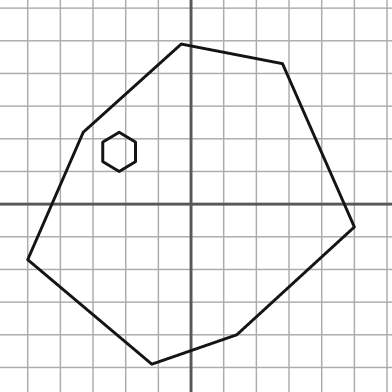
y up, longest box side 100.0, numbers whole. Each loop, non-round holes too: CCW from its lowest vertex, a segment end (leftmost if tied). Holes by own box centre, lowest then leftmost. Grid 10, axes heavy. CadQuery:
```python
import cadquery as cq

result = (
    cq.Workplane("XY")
    .moveTo(-12.0, -49.0)
    .lineTo(14.0, -40.0)
    .lineTo(50.0, -7.0)
    .lineTo(28.0, 43.0)
    .lineTo(-3.0, 49.0)
    .lineTo(-33.0, 22.0)
    .lineTo(-50.0, -17.0)
    .close()
    .moveTo(-22.0, 10.0)
    .lineTo(-17.0, 13.0)
    .lineTo(-17.0, 19.0)
    .lineTo(-22.0, 22.0)
    .lineTo(-27.0, 19.0)
    .lineTo(-27.0, 13.0)
    .close()
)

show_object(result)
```